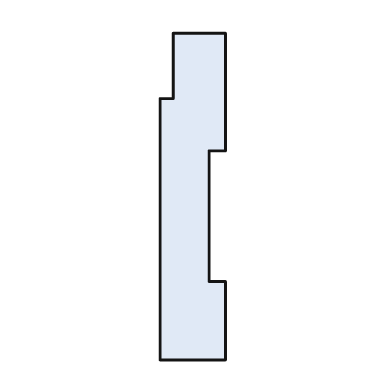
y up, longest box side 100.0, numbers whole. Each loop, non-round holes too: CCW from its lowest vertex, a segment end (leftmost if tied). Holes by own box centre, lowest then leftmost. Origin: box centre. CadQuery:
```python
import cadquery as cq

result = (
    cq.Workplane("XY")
    .moveTo(-10.0, -50.0)
    .lineTo(10.0, -50.0)
    .lineTo(10.0, -26.0)
    .lineTo(5.0, -26.0)
    .lineTo(5.0, 14.0)
    .lineTo(10.0, 14.0)
    .lineTo(10.0, 50.0)
    .lineTo(-6.0, 50.0)
    .lineTo(-6.0, 30.0)
    .lineTo(-10.0, 30.0)
    .close()
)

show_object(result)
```